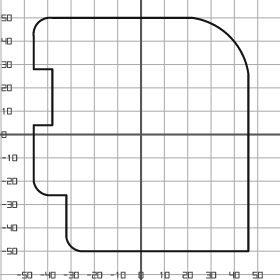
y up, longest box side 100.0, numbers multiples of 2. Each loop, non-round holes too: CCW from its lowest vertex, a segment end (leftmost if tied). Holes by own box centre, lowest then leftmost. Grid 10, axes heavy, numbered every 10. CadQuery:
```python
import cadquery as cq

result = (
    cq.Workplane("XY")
    .moveTo(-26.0, -50.0)
    .lineTo(46.0, -50.0)
    .lineTo(46.0, 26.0)
    .threePointArc((38.0, 42.0), (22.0, 50.0))
    .lineTo(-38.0, 50.0)
    .threePointArc((-44.0, 48.0), (-46.0, 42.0))
    .lineTo(-46.0, 28.0)
    .lineTo(-38.0, 28.0)
    .lineTo(-38.0, 4.0)
    .lineTo(-46.0, 4.0)
    .lineTo(-46.0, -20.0)
    .threePointArc((-44.0, -24.0), (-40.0, -26.0))
    .lineTo(-32.0, -26.0)
    .lineTo(-32.0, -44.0)
    .threePointArc((-30.0, -48.0), (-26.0, -50.0))
    .close()
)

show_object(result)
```